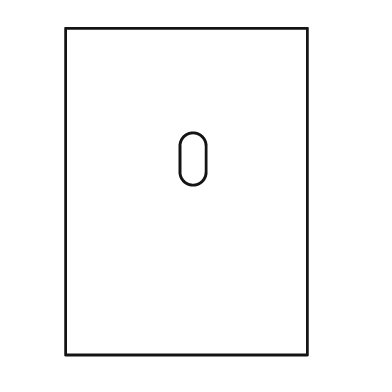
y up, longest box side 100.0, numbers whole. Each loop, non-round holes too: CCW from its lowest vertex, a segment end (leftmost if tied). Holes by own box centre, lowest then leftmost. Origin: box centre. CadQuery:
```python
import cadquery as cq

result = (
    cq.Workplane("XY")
    .moveTo(-37.0, -50.0)
    .lineTo(37.0, -50.0)
    .lineTo(37.0, 50.0)
    .lineTo(-37.0, 50.0)
    .close()
    .moveTo(-2.0, 6.0)
    .threePointArc((2.0, 2.0), (6.0, 6.0))
    .lineTo(6.0, 14.0)
    .threePointArc((2.0, 18.0), (-2.0, 14.0))
    .close()
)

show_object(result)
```